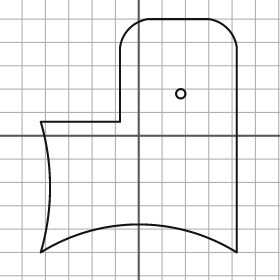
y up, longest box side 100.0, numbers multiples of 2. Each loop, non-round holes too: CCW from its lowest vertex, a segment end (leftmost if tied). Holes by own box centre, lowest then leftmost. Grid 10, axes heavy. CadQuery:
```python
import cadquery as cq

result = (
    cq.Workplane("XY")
    .moveTo(-42.0, -50.0)
    .threePointArc((0.0, -38.0), (42.0, -50.0))
    .lineTo(42.0, 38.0)
    .threePointArc((38.0, 46.0), (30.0, 50.0))
    .lineTo(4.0, 50.0)
    .threePointArc((-4.0, 46.0), (-8.0, 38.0))
    .lineTo(-8.0, 6.0)
    .lineTo(-42.0, 6.0)
    .threePointArc((-38.0, -22.0), (-42.0, -50.0))
    .close()
    .moveTo(18.0, 18.0)
    .circle(2.0)
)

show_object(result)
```